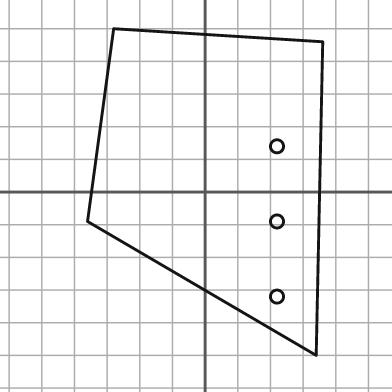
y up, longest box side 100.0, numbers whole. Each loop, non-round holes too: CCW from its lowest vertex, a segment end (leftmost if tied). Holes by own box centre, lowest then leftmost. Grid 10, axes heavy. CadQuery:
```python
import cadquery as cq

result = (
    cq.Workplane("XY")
    .moveTo(34.0, -50.0)
    .lineTo(36.0, 46.0)
    .lineTo(-28.0, 50.0)
    .lineTo(-36.0, -9.0)
    .close()
    .moveTo(22.0, -32.0)
    .circle(2.0)
    .moveTo(22.0, -9.0)
    .circle(2.0)
    .moveTo(22.0, 14.0)
    .circle(2.0)
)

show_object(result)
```